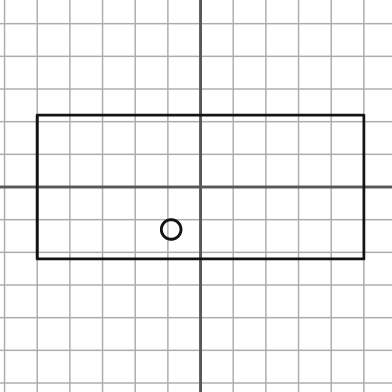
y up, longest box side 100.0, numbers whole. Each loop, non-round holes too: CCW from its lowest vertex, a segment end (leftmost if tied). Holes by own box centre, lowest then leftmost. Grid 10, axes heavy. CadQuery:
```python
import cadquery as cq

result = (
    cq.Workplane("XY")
    .moveTo(-50.0, -22.0)
    .lineTo(50.0, -22.0)
    .lineTo(50.0, 22.0)
    .lineTo(-50.0, 22.0)
    .close()
    .moveTo(-9.0, -13.0)
    .circle(3.0)
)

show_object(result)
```